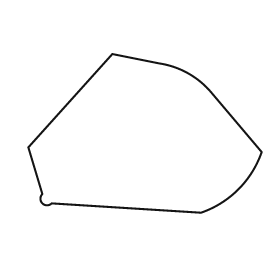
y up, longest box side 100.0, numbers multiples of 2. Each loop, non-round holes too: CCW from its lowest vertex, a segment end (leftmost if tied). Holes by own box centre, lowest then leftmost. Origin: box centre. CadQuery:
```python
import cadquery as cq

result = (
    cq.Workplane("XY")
    .moveTo(24.0, -34.0)
    .threePointArc((40.0, -24.0), (50.0, -8.0))
    .lineTo(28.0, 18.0)
    .threePointArc((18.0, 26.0), (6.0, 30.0))
    .lineTo(-14.0, 34.0)
    .lineTo(-50.0, -6.0)
    .lineTo(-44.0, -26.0)
    .threePointArc((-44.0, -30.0), (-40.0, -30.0))
    .close()
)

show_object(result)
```